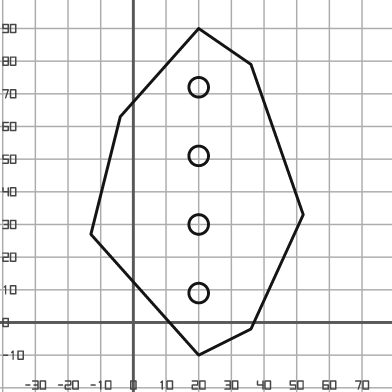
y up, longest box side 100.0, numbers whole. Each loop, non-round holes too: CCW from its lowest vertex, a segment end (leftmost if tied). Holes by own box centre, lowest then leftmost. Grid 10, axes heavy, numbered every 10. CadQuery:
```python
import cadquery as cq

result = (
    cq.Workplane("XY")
    .moveTo(20.0, -10.0)
    .lineTo(36.0, -2.0)
    .lineTo(52.0, 33.0)
    .lineTo(36.0, 79.0)
    .lineTo(20.0, 90.0)
    .lineTo(-4.0, 63.0)
    .lineTo(-13.0, 27.0)
    .close()
    .moveTo(20.0, 9.0)
    .circle(3.0)
    .moveTo(20.0, 30.0)
    .circle(3.0)
    .moveTo(20.0, 51.0)
    .circle(3.0)
    .moveTo(20.0, 72.0)
    .circle(3.0)
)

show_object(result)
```